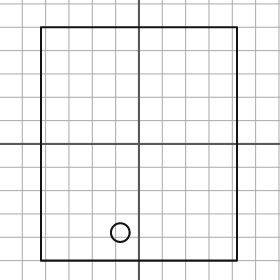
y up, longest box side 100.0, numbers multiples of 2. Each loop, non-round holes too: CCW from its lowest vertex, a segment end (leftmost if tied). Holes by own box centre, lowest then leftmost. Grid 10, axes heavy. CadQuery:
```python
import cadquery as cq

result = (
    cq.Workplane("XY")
    .moveTo(-42.0, -50.0)
    .lineTo(42.0, -50.0)
    .lineTo(42.0, 50.0)
    .lineTo(-42.0, 50.0)
    .close()
    .moveTo(-8.0, -38.0)
    .circle(4.0)
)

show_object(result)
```